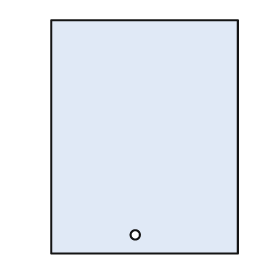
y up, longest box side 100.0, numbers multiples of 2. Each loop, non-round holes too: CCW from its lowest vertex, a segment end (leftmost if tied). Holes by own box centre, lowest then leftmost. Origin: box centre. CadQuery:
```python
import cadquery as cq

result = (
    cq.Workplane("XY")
    .moveTo(-40.0, -50.0)
    .lineTo(40.0, -50.0)
    .lineTo(40.0, 50.0)
    .lineTo(-40.0, 50.0)
    .close()
    .moveTo(-4.0, -42.0)
    .circle(2.0)
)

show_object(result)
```